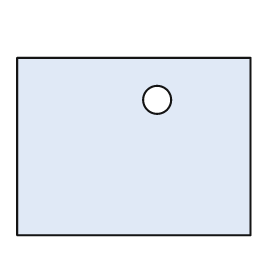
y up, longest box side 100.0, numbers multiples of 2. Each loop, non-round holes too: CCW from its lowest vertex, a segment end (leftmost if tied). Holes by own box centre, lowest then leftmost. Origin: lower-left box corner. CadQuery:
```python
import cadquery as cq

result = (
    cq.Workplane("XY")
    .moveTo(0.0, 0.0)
    .lineTo(100.0, 0.0)
    .lineTo(100.0, 76.0)
    .lineTo(0.0, 76.0)
    .close()
    .moveTo(60.0, 58.0)
    .circle(6.0)
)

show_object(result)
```